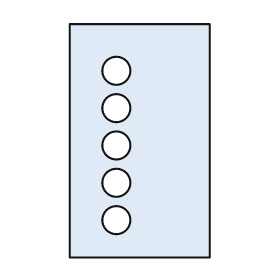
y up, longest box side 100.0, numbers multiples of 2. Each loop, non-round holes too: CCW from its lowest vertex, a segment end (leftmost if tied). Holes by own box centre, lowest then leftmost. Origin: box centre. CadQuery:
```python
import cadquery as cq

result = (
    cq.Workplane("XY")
    .moveTo(-30.0, -50.0)
    .lineTo(30.0, -50.0)
    .lineTo(30.0, 50.0)
    .lineTo(-30.0, 50.0)
    .close()
    .moveTo(-10.0, -34.0)
    .circle(6.0)
    .moveTo(-10.0, -18.0)
    .circle(6.0)
    .moveTo(-10.0, -2.0)
    .circle(6.0)
    .moveTo(-10.0, 14.0)
    .circle(6.0)
    .moveTo(-10.0, 30.0)
    .circle(6.0)
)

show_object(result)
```